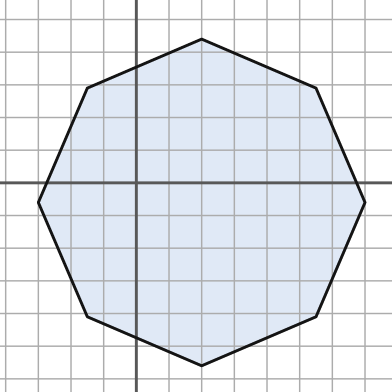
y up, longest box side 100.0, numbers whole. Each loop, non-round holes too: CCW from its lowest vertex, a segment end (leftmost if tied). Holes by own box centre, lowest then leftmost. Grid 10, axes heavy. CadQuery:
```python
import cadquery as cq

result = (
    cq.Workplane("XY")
    .moveTo(20.0, -56.0)
    .lineTo(55.0, -41.0)
    .lineTo(70.0, -6.0)
    .lineTo(55.0, 29.0)
    .lineTo(20.0, 44.0)
    .lineTo(-15.0, 29.0)
    .lineTo(-30.0, -6.0)
    .lineTo(-15.0, -41.0)
    .close()
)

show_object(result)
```